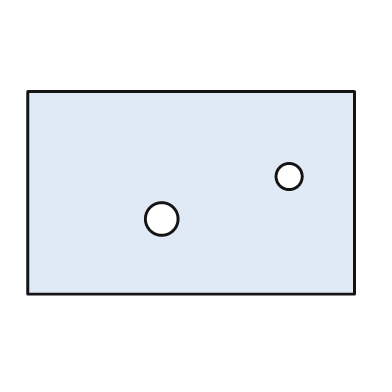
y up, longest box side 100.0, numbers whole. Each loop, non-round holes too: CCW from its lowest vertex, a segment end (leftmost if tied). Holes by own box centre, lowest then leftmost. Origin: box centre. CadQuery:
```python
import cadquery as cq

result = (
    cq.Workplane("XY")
    .moveTo(-50.0, -31.0)
    .lineTo(50.0, -31.0)
    .lineTo(50.0, 31.0)
    .lineTo(-50.0, 31.0)
    .close()
    .moveTo(-9.0, -8.0)
    .circle(5.0)
    .moveTo(30.0, 5.0)
    .circle(4.0)
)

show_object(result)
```